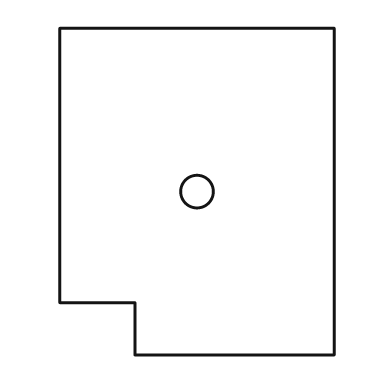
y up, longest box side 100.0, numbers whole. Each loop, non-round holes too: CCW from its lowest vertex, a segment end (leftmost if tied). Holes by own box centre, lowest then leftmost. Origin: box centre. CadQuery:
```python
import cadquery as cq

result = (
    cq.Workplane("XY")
    .moveTo(-19.0, -50.0)
    .lineTo(42.0, -50.0)
    .lineTo(42.0, 50.0)
    .lineTo(-42.0, 50.0)
    .lineTo(-42.0, -34.0)
    .lineTo(-19.0, -34.0)
    .close()
    .moveTo(0.0, 0.0)
    .circle(5.0)
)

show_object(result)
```